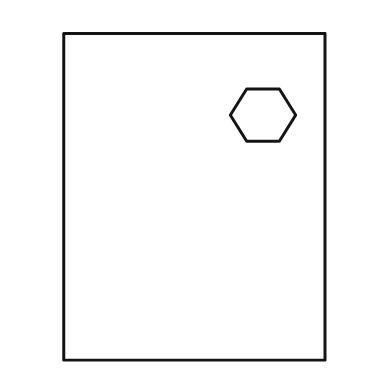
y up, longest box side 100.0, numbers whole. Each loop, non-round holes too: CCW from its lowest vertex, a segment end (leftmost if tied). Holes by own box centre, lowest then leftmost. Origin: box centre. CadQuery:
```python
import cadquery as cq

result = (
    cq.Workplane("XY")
    .moveTo(-40.0, -50.0)
    .lineTo(40.0, -50.0)
    .lineTo(40.0, 50.0)
    .lineTo(-40.0, 50.0)
    .close()
    .moveTo(16.0, 17.0)
    .lineTo(26.0, 17.0)
    .lineTo(31.0, 25.0)
    .lineTo(26.0, 33.0)
    .lineTo(16.0, 33.0)
    .lineTo(11.0, 25.0)
    .close()
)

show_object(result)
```